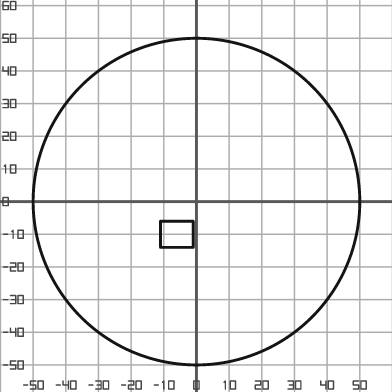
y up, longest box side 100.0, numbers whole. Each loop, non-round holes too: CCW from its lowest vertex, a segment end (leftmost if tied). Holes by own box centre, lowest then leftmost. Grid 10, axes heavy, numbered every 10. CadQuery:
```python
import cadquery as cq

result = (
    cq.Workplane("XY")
    .moveTo(0.0, 0.0)
    .circle(50.0)
    .moveTo(-11.0, -14.0)
    .lineTo(-1.0, -14.0)
    .lineTo(-1.0, -6.0)
    .lineTo(-11.0, -6.0)
    .close()
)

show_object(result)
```